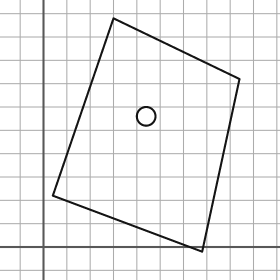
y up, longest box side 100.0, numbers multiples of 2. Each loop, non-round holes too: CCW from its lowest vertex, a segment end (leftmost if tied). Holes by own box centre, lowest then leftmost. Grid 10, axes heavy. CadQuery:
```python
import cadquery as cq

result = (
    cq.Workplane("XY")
    .moveTo(68.0, -2.0)
    .lineTo(84.0, 72.0)
    .lineTo(30.0, 98.0)
    .lineTo(4.0, 22.0)
    .close()
    .moveTo(44.0, 56.0)
    .circle(4.0)
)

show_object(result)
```